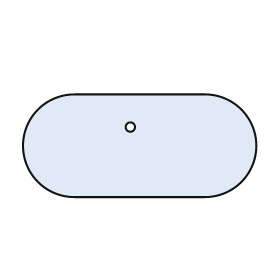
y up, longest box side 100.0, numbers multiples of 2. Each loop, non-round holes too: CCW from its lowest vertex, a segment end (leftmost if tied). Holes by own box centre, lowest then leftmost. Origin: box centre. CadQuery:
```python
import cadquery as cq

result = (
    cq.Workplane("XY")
    .moveTo(-28.0, -22.0)
    .lineTo(28.0, -22.0)
    .threePointArc((50.0, 0.0), (28.0, 22.0))
    .lineTo(-28.0, 22.0)
    .threePointArc((-50.0, 0.0), (-28.0, -22.0))
    .close()
    .moveTo(-4.0, 8.0)
    .circle(2.0)
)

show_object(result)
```